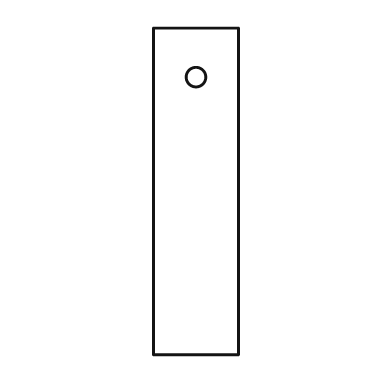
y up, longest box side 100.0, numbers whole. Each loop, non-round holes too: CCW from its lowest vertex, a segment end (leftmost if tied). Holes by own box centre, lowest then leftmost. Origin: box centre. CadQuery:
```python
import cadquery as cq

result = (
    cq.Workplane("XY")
    .moveTo(-13.0, -50.0)
    .lineTo(13.0, -50.0)
    .lineTo(13.0, 50.0)
    .lineTo(-13.0, 50.0)
    .close()
    .moveTo(0.0, 35.0)
    .circle(3.0)
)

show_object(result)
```